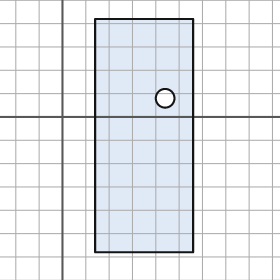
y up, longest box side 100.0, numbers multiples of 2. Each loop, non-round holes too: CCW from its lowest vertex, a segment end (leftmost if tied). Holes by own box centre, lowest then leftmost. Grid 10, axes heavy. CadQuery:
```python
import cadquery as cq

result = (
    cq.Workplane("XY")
    .moveTo(14.0, -58.0)
    .lineTo(56.0, -58.0)
    .lineTo(56.0, 42.0)
    .lineTo(14.0, 42.0)
    .close()
    .moveTo(44.0, 8.0)
    .circle(4.0)
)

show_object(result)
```